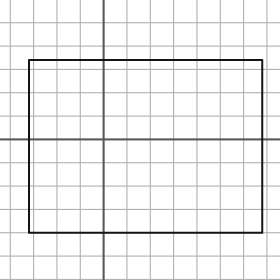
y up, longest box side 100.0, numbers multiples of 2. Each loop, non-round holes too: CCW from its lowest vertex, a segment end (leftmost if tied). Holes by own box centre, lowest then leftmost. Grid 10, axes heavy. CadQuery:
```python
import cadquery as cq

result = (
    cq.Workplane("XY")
    .moveTo(-32.0, -40.0)
    .lineTo(68.0, -40.0)
    .lineTo(68.0, 34.0)
    .lineTo(-32.0, 34.0)
    .close()
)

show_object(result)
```